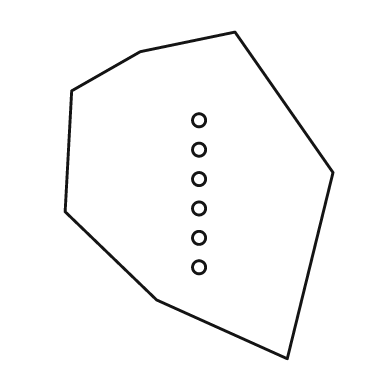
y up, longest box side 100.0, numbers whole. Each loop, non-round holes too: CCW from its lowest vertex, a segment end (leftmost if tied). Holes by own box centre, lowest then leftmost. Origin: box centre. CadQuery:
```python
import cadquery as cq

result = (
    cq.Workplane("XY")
    .moveTo(27.0, -50.0)
    .lineTo(41.0, 7.0)
    .lineTo(11.0, 50.0)
    .lineTo(-18.0, 44.0)
    .lineTo(-39.0, 32.0)
    .lineTo(-41.0, -5.0)
    .lineTo(-13.0, -32.0)
    .close()
    .moveTo(0.0, -22.0)
    .circle(2.0)
    .moveTo(0.0, -13.0)
    .circle(2.0)
    .moveTo(0.0, -4.0)
    .circle(2.0)
    .moveTo(0.0, 5.0)
    .circle(2.0)
    .moveTo(0.0, 14.0)
    .circle(2.0)
    .moveTo(0.0, 23.0)
    .circle(2.0)
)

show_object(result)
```